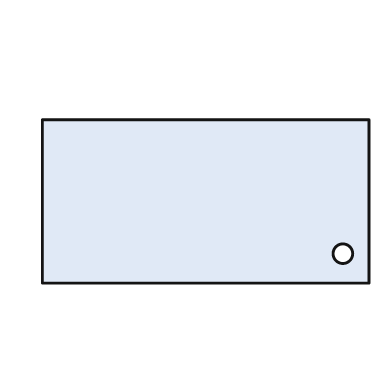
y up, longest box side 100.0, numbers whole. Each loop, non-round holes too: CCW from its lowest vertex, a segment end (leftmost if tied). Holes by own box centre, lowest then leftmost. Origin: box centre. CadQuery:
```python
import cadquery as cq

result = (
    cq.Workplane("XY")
    .moveTo(-50.0, -25.0)
    .lineTo(50.0, -25.0)
    .lineTo(50.0, 25.0)
    .lineTo(-50.0, 25.0)
    .close()
    .moveTo(42.0, -16.0)
    .circle(3.0)
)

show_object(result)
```